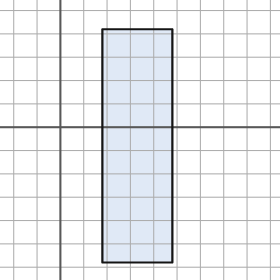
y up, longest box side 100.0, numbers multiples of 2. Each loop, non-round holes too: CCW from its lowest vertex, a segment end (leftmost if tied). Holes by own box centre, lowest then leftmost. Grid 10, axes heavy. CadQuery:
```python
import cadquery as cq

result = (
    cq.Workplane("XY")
    .moveTo(18.0, -58.0)
    .lineTo(48.0, -58.0)
    .lineTo(48.0, 42.0)
    .lineTo(18.0, 42.0)
    .close()
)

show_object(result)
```